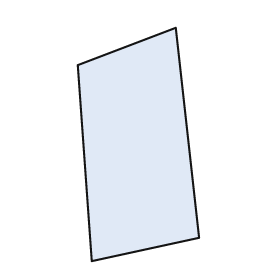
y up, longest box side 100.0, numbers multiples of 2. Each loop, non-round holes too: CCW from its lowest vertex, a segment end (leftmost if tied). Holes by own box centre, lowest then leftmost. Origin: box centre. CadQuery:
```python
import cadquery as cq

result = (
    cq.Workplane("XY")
    .moveTo(-20.0, -50.0)
    .lineTo(26.0, -40.0)
    .lineTo(16.0, 50.0)
    .lineTo(-26.0, 34.0)
    .close()
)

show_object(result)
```